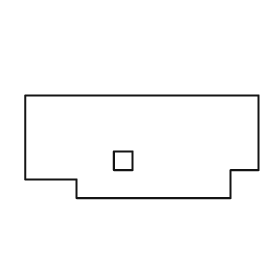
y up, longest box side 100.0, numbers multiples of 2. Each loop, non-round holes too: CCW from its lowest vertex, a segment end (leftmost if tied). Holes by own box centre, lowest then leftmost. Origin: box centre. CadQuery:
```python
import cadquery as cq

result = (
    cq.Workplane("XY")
    .moveTo(-28.0, -22.0)
    .lineTo(38.0, -22.0)
    .lineTo(38.0, -10.0)
    .lineTo(50.0, -10.0)
    .lineTo(50.0, 22.0)
    .lineTo(-50.0, 22.0)
    .lineTo(-50.0, -14.0)
    .lineTo(-28.0, -14.0)
    .close()
    .moveTo(-12.0, -10.0)
    .lineTo(-4.0, -10.0)
    .lineTo(-4.0, -2.0)
    .lineTo(-12.0, -2.0)
    .close()
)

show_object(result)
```